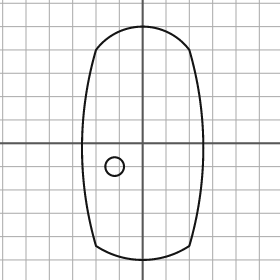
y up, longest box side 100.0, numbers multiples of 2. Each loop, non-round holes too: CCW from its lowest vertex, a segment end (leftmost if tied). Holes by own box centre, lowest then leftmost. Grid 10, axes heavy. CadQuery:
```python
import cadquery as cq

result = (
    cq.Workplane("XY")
    .moveTo(-20.0, -44.0)
    .threePointArc((0.0, -50.0), (20.0, -44.0))
    .threePointArc((26.0, -2.0), (20.0, 40.0))
    .threePointArc((0.0, 50.0), (-20.0, 40.0))
    .threePointArc((-26.0, -2.0), (-20.0, -44.0))
    .close()
    .moveTo(-12.0, -10.0)
    .circle(4.0)
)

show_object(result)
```